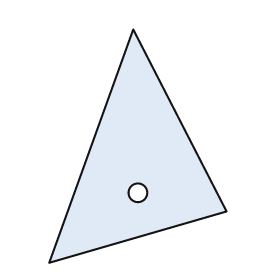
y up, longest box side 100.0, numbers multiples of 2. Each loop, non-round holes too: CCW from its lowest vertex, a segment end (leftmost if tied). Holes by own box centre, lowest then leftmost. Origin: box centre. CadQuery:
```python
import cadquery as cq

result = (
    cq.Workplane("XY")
    .moveTo(-38.0, -50.0)
    .lineTo(38.0, -28.0)
    .lineTo(-2.0, 50.0)
    .close()
    .moveTo(0.0, -20.0)
    .circle(4.0)
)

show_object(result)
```